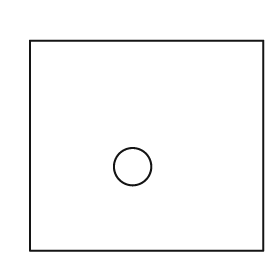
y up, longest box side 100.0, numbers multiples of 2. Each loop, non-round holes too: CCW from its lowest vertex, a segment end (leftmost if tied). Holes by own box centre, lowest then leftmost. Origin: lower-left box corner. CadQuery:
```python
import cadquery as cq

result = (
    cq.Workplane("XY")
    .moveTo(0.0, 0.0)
    .lineTo(100.0, 0.0)
    .lineTo(100.0, 90.0)
    .lineTo(0.0, 90.0)
    .close()
    .moveTo(44.0, 36.0)
    .circle(8.0)
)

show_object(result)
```